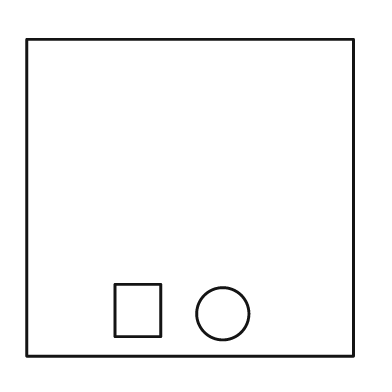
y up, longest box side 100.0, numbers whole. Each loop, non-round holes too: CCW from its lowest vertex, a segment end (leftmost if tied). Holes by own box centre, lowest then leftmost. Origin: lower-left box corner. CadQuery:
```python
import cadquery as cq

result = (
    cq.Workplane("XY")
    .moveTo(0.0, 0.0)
    .lineTo(100.0, 0.0)
    .lineTo(100.0, 97.0)
    .lineTo(0.0, 97.0)
    .close()
    .moveTo(60.0, 13.0)
    .circle(8.0)
    .moveTo(27.0, 6.0)
    .lineTo(41.0, 6.0)
    .lineTo(41.0, 22.0)
    .lineTo(27.0, 22.0)
    .close()
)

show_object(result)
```